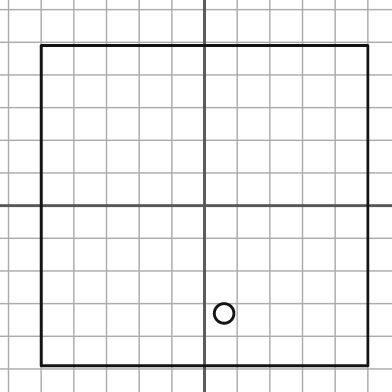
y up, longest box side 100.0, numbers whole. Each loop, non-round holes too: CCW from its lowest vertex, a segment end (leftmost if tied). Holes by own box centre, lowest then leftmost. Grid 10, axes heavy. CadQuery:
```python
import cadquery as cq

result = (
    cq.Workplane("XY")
    .moveTo(-50.0, -49.0)
    .lineTo(50.0, -49.0)
    .lineTo(50.0, 49.0)
    .lineTo(-50.0, 49.0)
    .close()
    .moveTo(6.0, -33.0)
    .circle(3.0)
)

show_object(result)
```